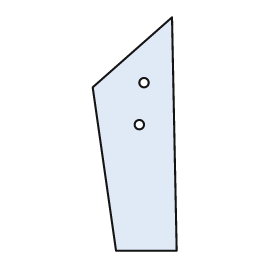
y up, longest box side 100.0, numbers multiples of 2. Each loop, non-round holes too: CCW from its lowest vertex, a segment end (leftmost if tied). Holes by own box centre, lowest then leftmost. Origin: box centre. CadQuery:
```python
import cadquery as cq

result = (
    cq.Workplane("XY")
    .moveTo(-8.0, -50.0)
    .lineTo(18.0, -50.0)
    .lineTo(16.0, 50.0)
    .lineTo(-18.0, 20.0)
    .close()
    .moveTo(2.0, 4.0)
    .circle(2.0)
    .moveTo(4.0, 22.0)
    .circle(2.0)
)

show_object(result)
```